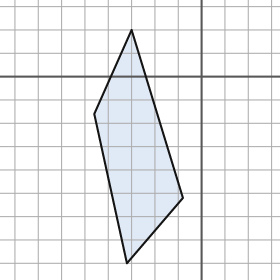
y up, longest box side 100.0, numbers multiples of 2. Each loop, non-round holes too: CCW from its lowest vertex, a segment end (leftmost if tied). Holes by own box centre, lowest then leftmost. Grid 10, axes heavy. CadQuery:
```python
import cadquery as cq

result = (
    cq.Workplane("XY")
    .moveTo(-32.0, -80.0)
    .lineTo(-8.0, -52.0)
    .lineTo(-30.0, 20.0)
    .lineTo(-46.0, -16.0)
    .close()
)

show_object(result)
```